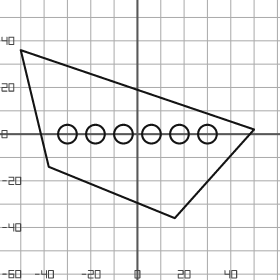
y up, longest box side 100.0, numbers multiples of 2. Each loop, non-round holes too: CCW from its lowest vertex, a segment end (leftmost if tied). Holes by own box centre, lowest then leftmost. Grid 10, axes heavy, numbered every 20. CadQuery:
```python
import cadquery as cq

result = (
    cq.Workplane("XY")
    .moveTo(16.0, -36.0)
    .lineTo(50.0, 2.0)
    .lineTo(-50.0, 36.0)
    .lineTo(-38.0, -14.0)
    .close()
    .moveTo(-30.0, 0.0)
    .circle(4.0)
    .moveTo(-18.0, 0.0)
    .circle(4.0)
    .moveTo(-6.0, 0.0)
    .circle(4.0)
    .moveTo(6.0, 0.0)
    .circle(4.0)
    .moveTo(18.0, 0.0)
    .circle(4.0)
    .moveTo(30.0, 0.0)
    .circle(4.0)
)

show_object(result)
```